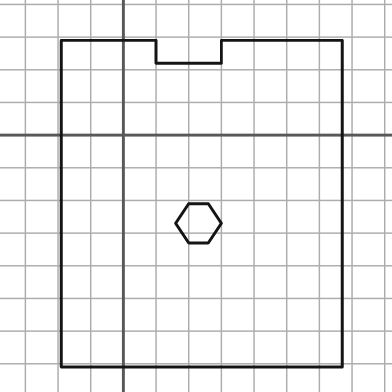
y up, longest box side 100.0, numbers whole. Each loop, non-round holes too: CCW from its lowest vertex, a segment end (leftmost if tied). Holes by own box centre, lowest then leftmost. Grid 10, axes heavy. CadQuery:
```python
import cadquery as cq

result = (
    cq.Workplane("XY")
    .moveTo(-19.0, -71.0)
    .lineTo(67.0, -71.0)
    .lineTo(67.0, 29.0)
    .lineTo(30.0, 29.0)
    .lineTo(30.0, 22.0)
    .lineTo(10.0, 22.0)
    .lineTo(10.0, 29.0)
    .lineTo(-19.0, 29.0)
    .close()
    .moveTo(20.0, -33.0)
    .lineTo(26.0, -33.0)
    .lineTo(30.0, -27.0)
    .lineTo(26.0, -21.0)
    .lineTo(20.0, -21.0)
    .lineTo(16.0, -27.0)
    .close()
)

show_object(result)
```